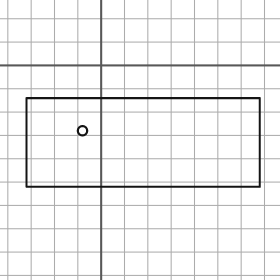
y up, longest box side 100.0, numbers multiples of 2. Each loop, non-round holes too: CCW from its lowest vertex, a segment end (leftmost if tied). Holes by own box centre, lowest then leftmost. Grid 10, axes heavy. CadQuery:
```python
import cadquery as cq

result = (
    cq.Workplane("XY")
    .moveTo(-32.0, -52.0)
    .lineTo(68.0, -52.0)
    .lineTo(68.0, -14.0)
    .lineTo(-32.0, -14.0)
    .close()
    .moveTo(-8.0, -28.0)
    .circle(2.0)
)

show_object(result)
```